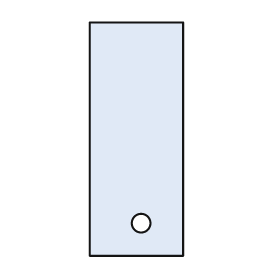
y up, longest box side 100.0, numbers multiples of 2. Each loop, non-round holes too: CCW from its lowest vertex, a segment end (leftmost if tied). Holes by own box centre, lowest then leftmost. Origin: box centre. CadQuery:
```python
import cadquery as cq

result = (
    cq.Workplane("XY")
    .moveTo(-20.0, -50.0)
    .lineTo(20.0, -50.0)
    .lineTo(20.0, 50.0)
    .lineTo(-20.0, 50.0)
    .close()
    .moveTo(2.0, -36.0)
    .circle(4.0)
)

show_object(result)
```